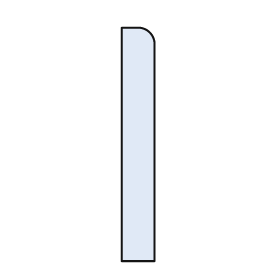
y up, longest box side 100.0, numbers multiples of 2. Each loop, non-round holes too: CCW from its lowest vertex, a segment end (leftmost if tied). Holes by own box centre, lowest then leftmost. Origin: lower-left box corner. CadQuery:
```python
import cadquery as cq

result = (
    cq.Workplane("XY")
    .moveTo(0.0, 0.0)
    .lineTo(14.0, 0.0)
    .lineTo(14.0, 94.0)
    .threePointArc((12.0, 98.0), (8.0, 100.0))
    .lineTo(0.0, 100.0)
    .close()
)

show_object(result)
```